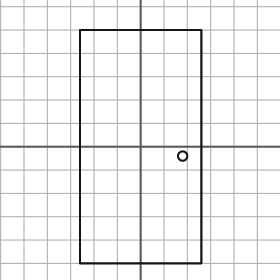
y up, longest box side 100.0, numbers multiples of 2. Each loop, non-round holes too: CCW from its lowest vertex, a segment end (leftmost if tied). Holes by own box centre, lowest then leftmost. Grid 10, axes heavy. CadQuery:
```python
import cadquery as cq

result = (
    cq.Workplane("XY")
    .moveTo(-26.0, -50.0)
    .lineTo(26.0, -50.0)
    .lineTo(26.0, 50.0)
    .lineTo(-26.0, 50.0)
    .close()
    .moveTo(18.0, -4.0)
    .circle(2.0)
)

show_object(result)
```